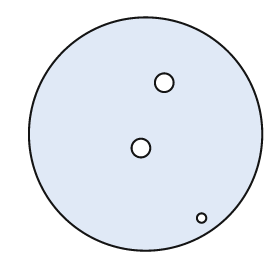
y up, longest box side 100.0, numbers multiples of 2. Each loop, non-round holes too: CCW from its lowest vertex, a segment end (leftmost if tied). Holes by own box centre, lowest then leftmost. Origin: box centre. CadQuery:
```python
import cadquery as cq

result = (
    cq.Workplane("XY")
    .moveTo(0.0, 0.0)
    .circle(50.0)
    .moveTo(24.0, -36.0)
    .circle(2.0)
    .moveTo(-2.0, -6.0)
    .circle(4.0)
    .moveTo(8.0, 22.0)
    .circle(4.0)
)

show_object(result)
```